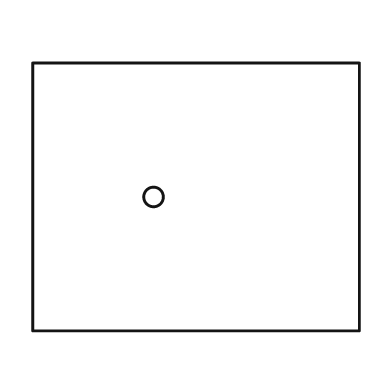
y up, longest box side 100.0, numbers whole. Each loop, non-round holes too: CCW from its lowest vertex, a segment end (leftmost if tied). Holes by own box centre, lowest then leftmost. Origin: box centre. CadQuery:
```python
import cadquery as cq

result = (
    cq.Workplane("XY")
    .moveTo(-50.0, -41.0)
    .lineTo(50.0, -41.0)
    .lineTo(50.0, 41.0)
    .lineTo(-50.0, 41.0)
    .close()
    .moveTo(-13.0, 0.0)
    .circle(3.0)
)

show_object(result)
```